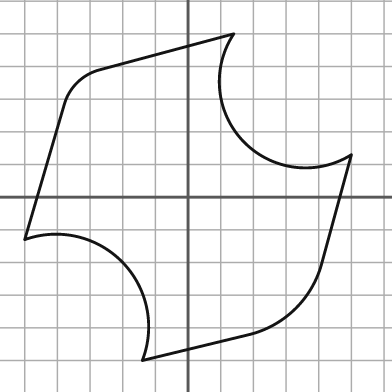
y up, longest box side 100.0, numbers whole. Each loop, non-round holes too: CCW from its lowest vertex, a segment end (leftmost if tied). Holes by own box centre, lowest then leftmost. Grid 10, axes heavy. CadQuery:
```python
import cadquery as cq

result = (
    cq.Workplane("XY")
    .moveTo(-14.0, -50.0)
    .lineTo(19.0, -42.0)
    .threePointArc((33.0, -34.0), (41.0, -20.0))
    .lineTo(50.0, 13.0)
    .threePointArc((17.0, 17.0), (14.0, 50.0))
    .lineTo(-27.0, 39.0)
    .threePointArc((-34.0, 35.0), (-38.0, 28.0))
    .lineTo(-50.0, -13.0)
    .threePointArc((-20.0, -20.0), (-14.0, -50.0))
    .close()
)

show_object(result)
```